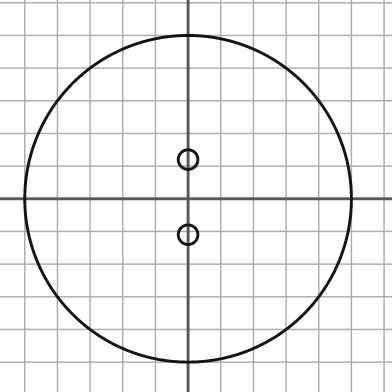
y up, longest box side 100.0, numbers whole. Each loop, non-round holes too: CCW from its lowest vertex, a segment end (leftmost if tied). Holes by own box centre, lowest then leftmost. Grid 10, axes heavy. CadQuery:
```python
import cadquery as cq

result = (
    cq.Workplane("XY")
    .moveTo(0.0, 0.0)
    .circle(50.0)
    .moveTo(0.0, -11.0)
    .circle(3.0)
    .moveTo(0.0, 12.0)
    .circle(3.0)
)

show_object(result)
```